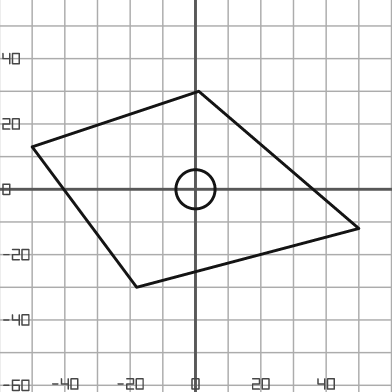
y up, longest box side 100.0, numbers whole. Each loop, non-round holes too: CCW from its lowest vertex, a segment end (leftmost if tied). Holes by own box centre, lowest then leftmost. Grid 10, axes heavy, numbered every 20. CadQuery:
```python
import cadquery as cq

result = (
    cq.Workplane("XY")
    .moveTo(-18.0, -30.0)
    .lineTo(50.0, -12.0)
    .lineTo(1.0, 30.0)
    .lineTo(-50.0, 13.0)
    .close()
    .moveTo(0.0, 0.0)
    .circle(6.0)
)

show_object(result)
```